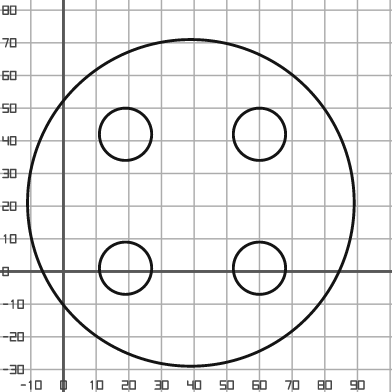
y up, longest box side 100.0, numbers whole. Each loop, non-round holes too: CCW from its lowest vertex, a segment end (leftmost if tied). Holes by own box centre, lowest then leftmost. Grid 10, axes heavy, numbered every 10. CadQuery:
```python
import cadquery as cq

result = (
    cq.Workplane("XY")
    .moveTo(39.0, 21.0)
    .circle(50.0)
    .moveTo(19.0, 1.0)
    .circle(8.0)
    .moveTo(60.0, 1.0)
    .circle(8.0)
    .moveTo(19.0, 42.0)
    .circle(8.0)
    .moveTo(60.0, 42.0)
    .circle(8.0)
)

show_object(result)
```